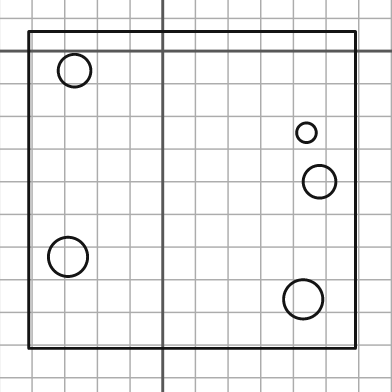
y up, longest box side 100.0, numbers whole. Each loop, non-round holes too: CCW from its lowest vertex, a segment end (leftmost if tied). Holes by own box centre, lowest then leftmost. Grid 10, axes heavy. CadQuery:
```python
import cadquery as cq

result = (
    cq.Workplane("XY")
    .moveTo(-41.0, -91.0)
    .lineTo(59.0, -91.0)
    .lineTo(59.0, 6.0)
    .lineTo(-41.0, 6.0)
    .close()
    .moveTo(43.0, -76.0)
    .circle(6.0)
    .moveTo(-29.0, -63.0)
    .circle(6.0)
    .moveTo(48.0, -40.0)
    .circle(5.0)
    .moveTo(44.0, -25.0)
    .circle(3.0)
    .moveTo(-27.0, -6.0)
    .circle(5.0)
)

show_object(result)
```